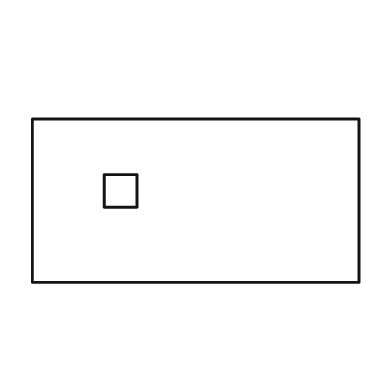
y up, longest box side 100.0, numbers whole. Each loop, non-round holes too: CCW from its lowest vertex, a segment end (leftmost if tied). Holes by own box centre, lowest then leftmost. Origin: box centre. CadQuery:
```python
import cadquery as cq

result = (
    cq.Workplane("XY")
    .moveTo(-50.0, -25.0)
    .lineTo(50.0, -25.0)
    .lineTo(50.0, 25.0)
    .lineTo(-50.0, 25.0)
    .close()
    .moveTo(-28.0, -2.0)
    .lineTo(-18.0, -2.0)
    .lineTo(-18.0, 8.0)
    .lineTo(-28.0, 8.0)
    .close()
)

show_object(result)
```